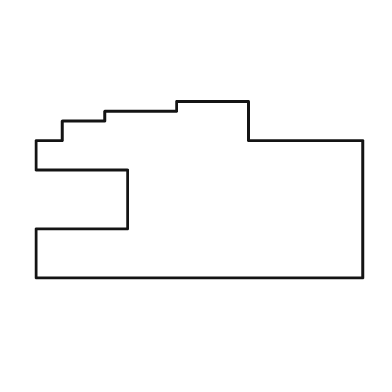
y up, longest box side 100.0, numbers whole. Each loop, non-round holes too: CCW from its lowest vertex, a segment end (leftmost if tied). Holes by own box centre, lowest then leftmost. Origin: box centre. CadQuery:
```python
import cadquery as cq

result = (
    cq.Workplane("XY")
    .moveTo(-50.0, -27.0)
    .lineTo(50.0, -27.0)
    .lineTo(50.0, 15.0)
    .lineTo(15.0, 15.0)
    .lineTo(15.0, 27.0)
    .lineTo(-7.0, 27.0)
    .lineTo(-7.0, 24.0)
    .lineTo(-29.0, 24.0)
    .lineTo(-29.0, 21.0)
    .lineTo(-42.0, 21.0)
    .lineTo(-42.0, 15.0)
    .lineTo(-50.0, 15.0)
    .lineTo(-50.0, 6.0)
    .lineTo(-22.0, 6.0)
    .lineTo(-22.0, -12.0)
    .lineTo(-50.0, -12.0)
    .close()
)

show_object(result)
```